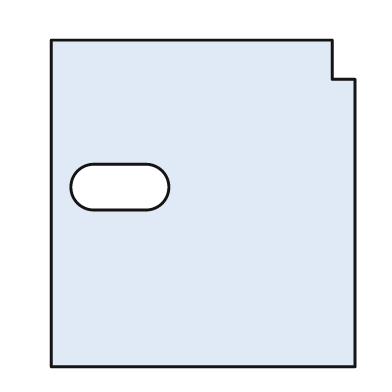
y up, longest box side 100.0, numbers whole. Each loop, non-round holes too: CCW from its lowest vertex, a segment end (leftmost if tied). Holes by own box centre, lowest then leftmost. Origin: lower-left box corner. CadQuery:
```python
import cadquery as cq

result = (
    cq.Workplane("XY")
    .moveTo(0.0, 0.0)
    .lineTo(93.0, 0.0)
    .lineTo(93.0, 88.0)
    .lineTo(86.0, 88.0)
    .lineTo(86.0, 100.0)
    .lineTo(0.0, 100.0)
    .close()
    .moveTo(13.0, 48.0)
    .lineTo(29.0, 48.0)
    .threePointArc((36.0, 55.0), (29.0, 62.0))
    .lineTo(13.0, 62.0)
    .threePointArc((6.0, 55.0), (13.0, 48.0))
    .close()
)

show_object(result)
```